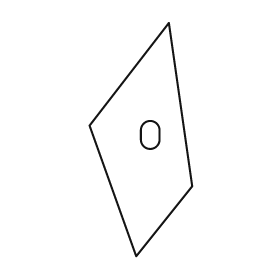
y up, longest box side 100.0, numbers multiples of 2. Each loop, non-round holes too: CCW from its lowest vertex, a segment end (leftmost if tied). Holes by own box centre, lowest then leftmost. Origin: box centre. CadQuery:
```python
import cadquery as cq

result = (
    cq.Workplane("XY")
    .moveTo(-2.0, -50.0)
    .lineTo(22.0, -20.0)
    .lineTo(12.0, 50.0)
    .lineTo(-22.0, 6.0)
    .close()
    .moveTo(0.0, 0.0)
    .threePointArc((4.0, -4.0), (8.0, 0.0))
    .lineTo(8.0, 4.0)
    .threePointArc((4.0, 8.0), (0.0, 4.0))
    .close()
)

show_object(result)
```